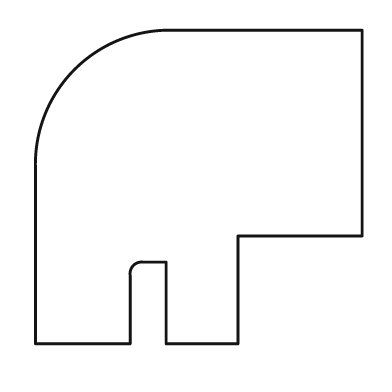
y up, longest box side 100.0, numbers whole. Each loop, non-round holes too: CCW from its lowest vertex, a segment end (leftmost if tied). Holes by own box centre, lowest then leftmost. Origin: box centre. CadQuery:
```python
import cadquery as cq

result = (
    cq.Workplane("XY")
    .moveTo(-50.0, -48.0)
    .lineTo(-21.0, -48.0)
    .lineTo(-21.0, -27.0)
    .threePointArc((-20.0, -24.0), (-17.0, -23.0))
    .lineTo(-10.0, -23.0)
    .lineTo(-10.0, -48.0)
    .lineTo(12.0, -48.0)
    .lineTo(12.0, -15.0)
    .lineTo(50.0, -15.0)
    .lineTo(50.0, 48.0)
    .lineTo(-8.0, 48.0)
    .threePointArc((-38.0, 36.0), (-50.0, 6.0))
    .close()
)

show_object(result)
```